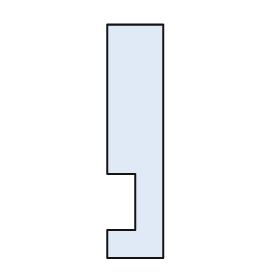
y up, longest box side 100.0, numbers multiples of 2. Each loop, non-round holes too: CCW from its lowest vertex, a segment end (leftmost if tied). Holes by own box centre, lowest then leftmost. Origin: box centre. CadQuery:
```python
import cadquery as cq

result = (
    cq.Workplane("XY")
    .moveTo(-12.0, -50.0)
    .lineTo(12.0, -50.0)
    .lineTo(12.0, 50.0)
    .lineTo(-12.0, 50.0)
    .lineTo(-12.0, -14.0)
    .lineTo(0.0, -14.0)
    .lineTo(0.0, -38.0)
    .lineTo(-12.0, -38.0)
    .close()
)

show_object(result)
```